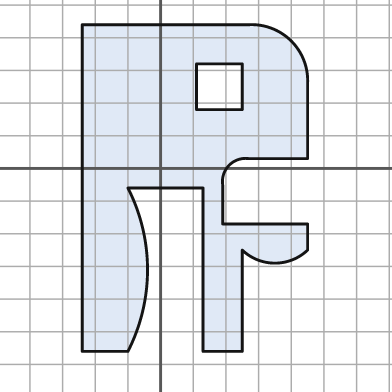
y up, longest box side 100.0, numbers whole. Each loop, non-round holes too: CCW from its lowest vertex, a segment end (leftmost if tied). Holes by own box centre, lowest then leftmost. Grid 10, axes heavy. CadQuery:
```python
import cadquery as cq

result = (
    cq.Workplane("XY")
    .moveTo(-24.0, -56.0)
    .lineTo(-10.0, -56.0)
    .threePointArc((-4.0, -31.0), (-10.0, -6.0))
    .lineTo(13.0, -6.0)
    .lineTo(13.0, -56.0)
    .lineTo(25.0, -56.0)
    .lineTo(25.0, -25.0)
    .threePointArc((35.0, -29.0), (45.0, -25.0))
    .lineTo(45.0, -17.0)
    .lineTo(19.0, -17.0)
    .lineTo(19.0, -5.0)
    .threePointArc((21.0, 1.0), (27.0, 3.0))
    .lineTo(45.0, 3.0)
    .lineTo(45.0, 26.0)
    .threePointArc((40.0, 39.0), (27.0, 44.0))
    .lineTo(-24.0, 44.0)
    .close()
    .moveTo(11.0, 18.0)
    .lineTo(25.0, 18.0)
    .lineTo(25.0, 32.0)
    .lineTo(11.0, 32.0)
    .close()
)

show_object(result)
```